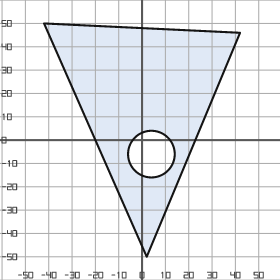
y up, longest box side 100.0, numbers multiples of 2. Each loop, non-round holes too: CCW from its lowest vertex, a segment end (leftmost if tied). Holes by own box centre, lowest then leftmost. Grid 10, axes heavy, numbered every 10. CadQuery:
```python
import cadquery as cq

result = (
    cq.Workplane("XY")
    .moveTo(2.0, -50.0)
    .lineTo(42.0, 46.0)
    .lineTo(-42.0, 50.0)
    .close()
    .moveTo(4.0, -6.0)
    .circle(10.0)
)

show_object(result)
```